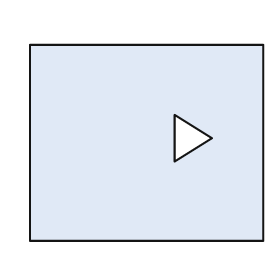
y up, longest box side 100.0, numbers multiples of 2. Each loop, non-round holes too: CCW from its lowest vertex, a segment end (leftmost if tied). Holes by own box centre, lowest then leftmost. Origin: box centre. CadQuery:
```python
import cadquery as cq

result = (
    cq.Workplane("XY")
    .moveTo(-50.0, -42.0)
    .lineTo(50.0, -42.0)
    .lineTo(50.0, 42.0)
    .lineTo(-50.0, 42.0)
    .close()
    .moveTo(12.0, -8.0)
    .lineTo(28.0, 2.0)
    .lineTo(12.0, 12.0)
    .close()
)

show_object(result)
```